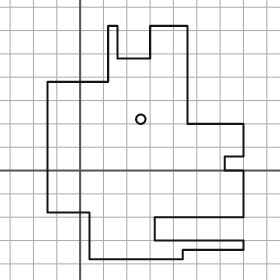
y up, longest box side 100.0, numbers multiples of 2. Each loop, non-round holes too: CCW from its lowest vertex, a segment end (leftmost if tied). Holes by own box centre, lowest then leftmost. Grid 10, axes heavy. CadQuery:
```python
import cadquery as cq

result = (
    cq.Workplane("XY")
    .moveTo(4.0, -38.0)
    .lineTo(44.0, -38.0)
    .lineTo(44.0, -34.0)
    .lineTo(70.0, -34.0)
    .lineTo(70.0, -30.0)
    .lineTo(32.0, -30.0)
    .lineTo(32.0, -20.0)
    .lineTo(70.0, -20.0)
    .lineTo(70.0, 0.0)
    .lineTo(62.0, 0.0)
    .lineTo(62.0, 6.0)
    .lineTo(70.0, 6.0)
    .lineTo(70.0, 20.0)
    .lineTo(46.0, 20.0)
    .lineTo(46.0, 62.0)
    .lineTo(30.0, 62.0)
    .lineTo(30.0, 48.0)
    .lineTo(16.0, 48.0)
    .lineTo(16.0, 62.0)
    .lineTo(12.0, 62.0)
    .lineTo(12.0, 38.0)
    .lineTo(-14.0, 38.0)
    .lineTo(-14.0, -18.0)
    .lineTo(4.0, -18.0)
    .close()
    .moveTo(26.0, 22.0)
    .circle(2.0)
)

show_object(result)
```